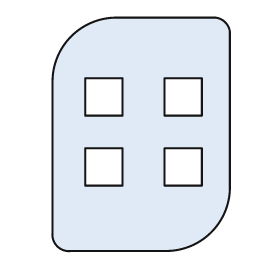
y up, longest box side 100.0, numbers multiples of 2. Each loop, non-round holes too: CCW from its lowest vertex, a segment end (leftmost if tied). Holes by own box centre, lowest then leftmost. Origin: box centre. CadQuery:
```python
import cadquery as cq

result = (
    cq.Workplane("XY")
    .moveTo(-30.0, -50.0)
    .lineTo(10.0, -50.0)
    .threePointArc((30.0, -42.0), (38.0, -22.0))
    .lineTo(38.0, 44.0)
    .threePointArc((36.0, 48.0), (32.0, 50.0))
    .lineTo(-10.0, 50.0)
    .threePointArc((-30.0, 42.0), (-38.0, 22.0))
    .lineTo(-38.0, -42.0)
    .threePointArc((-36.0, -48.0), (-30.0, -50.0))
    .close()
    .moveTo(-24.0, -22.0)
    .lineTo(-8.0, -22.0)
    .lineTo(-8.0, -6.0)
    .lineTo(-24.0, -6.0)
    .close()
    .moveTo(10.0, -22.0)
    .lineTo(26.0, -22.0)
    .lineTo(26.0, -6.0)
    .lineTo(10.0, -6.0)
    .close()
    .moveTo(-24.0, 8.0)
    .lineTo(-8.0, 8.0)
    .lineTo(-8.0, 24.0)
    .lineTo(-24.0, 24.0)
    .close()
    .moveTo(10.0, 8.0)
    .lineTo(26.0, 8.0)
    .lineTo(26.0, 24.0)
    .lineTo(10.0, 24.0)
    .close()
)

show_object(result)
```